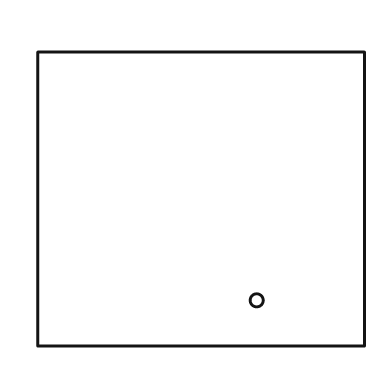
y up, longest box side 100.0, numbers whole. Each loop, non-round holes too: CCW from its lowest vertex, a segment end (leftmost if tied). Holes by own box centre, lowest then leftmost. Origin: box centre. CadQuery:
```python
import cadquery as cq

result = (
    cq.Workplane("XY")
    .moveTo(-50.0, -45.0)
    .lineTo(50.0, -45.0)
    .lineTo(50.0, 45.0)
    .lineTo(-50.0, 45.0)
    .close()
    .moveTo(17.0, -31.0)
    .circle(2.0)
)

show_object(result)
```